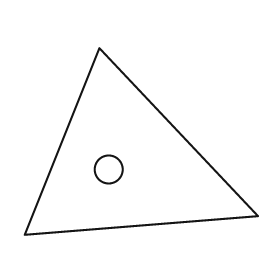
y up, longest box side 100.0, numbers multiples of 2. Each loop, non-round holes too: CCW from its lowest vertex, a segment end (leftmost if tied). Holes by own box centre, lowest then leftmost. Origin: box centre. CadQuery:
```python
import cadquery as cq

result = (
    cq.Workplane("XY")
    .moveTo(-50.0, -40.0)
    .lineTo(50.0, -32.0)
    .lineTo(-18.0, 40.0)
    .close()
    .moveTo(-14.0, -12.0)
    .circle(6.0)
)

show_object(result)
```